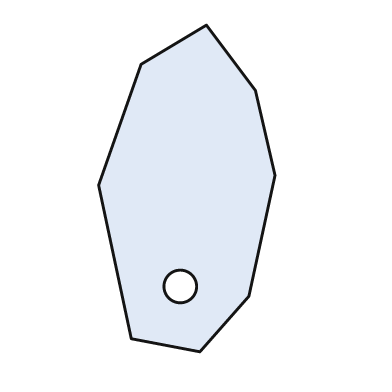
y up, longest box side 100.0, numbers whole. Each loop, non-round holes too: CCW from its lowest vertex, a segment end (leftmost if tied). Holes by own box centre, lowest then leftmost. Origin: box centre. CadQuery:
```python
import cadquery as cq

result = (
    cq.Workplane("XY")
    .moveTo(4.0, -50.0)
    .lineTo(19.0, -33.0)
    .lineTo(27.0, 4.0)
    .lineTo(21.0, 30.0)
    .lineTo(6.0, 50.0)
    .lineTo(-14.0, 38.0)
    .lineTo(-27.0, 1.0)
    .lineTo(-17.0, -46.0)
    .close()
    .moveTo(-2.0, -30.0)
    .circle(5.0)
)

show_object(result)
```